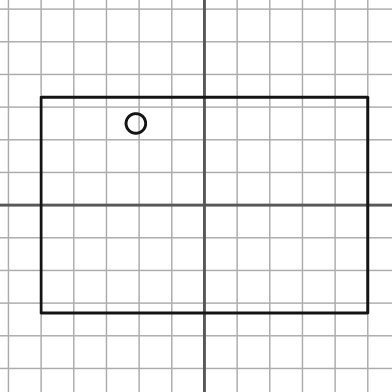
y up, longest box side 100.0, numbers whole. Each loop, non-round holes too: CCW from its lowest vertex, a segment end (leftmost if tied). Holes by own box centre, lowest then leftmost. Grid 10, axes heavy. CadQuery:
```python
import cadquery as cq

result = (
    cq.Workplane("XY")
    .moveTo(-50.0, -33.0)
    .lineTo(50.0, -33.0)
    .lineTo(50.0, 33.0)
    .lineTo(-50.0, 33.0)
    .close()
    .moveTo(-21.0, 25.0)
    .circle(3.0)
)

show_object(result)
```